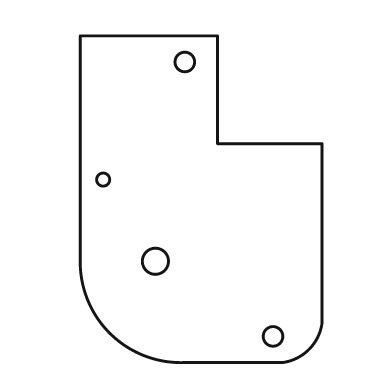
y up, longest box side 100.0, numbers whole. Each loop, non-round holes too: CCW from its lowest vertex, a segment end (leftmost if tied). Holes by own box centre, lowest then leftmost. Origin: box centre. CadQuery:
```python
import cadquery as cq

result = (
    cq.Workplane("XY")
    .moveTo(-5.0, -50.0)
    .lineTo(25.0, -50.0)
    .threePointArc((33.0, -46.0), (37.0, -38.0))
    .lineTo(37.0, 17.0)
    .lineTo(5.0, 17.0)
    .lineTo(5.0, 50.0)
    .lineTo(-37.0, 50.0)
    .lineTo(-37.0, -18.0)
    .threePointArc((-28.0, -41.0), (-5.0, -50.0))
    .close()
    .moveTo(22.0, -42.0)
    .circle(3.0)
    .moveTo(-14.0, -19.0)
    .circle(4.0)
    .moveTo(-30.0, 6.0)
    .circle(2.0)
    .moveTo(-5.0, 42.0)
    .circle(3.0)
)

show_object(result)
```